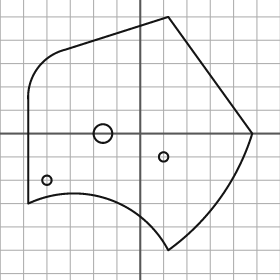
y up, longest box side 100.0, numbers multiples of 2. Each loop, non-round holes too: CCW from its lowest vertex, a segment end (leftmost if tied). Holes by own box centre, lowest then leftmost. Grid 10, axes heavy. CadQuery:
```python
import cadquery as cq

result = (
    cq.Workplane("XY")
    .moveTo(12.0, -50.0)
    .threePointArc((34.0, -28.0), (48.0, 0.0))
    .lineTo(12.0, 50.0)
    .lineTo(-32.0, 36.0)
    .threePointArc((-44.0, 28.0), (-48.0, 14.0))
    .lineTo(-48.0, -30.0)
    .threePointArc((-14.0, -28.0), (12.0, -50.0))
    .close()
    .moveTo(-40.0, -20.0)
    .circle(2.0)
    .moveTo(10.0, -10.0)
    .circle(2.0)
    .moveTo(-16.0, 0.0)
    .circle(4.0)
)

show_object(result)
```